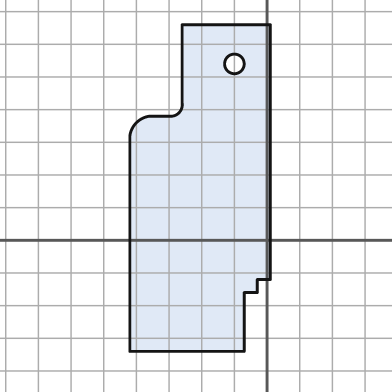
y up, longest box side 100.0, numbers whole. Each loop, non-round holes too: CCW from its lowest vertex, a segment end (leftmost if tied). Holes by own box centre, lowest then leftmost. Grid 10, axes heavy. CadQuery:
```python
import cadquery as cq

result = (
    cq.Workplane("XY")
    .moveTo(-42.0, -34.0)
    .lineTo(-7.0, -34.0)
    .lineTo(-7.0, -16.0)
    .lineTo(-3.0, -16.0)
    .lineTo(-3.0, -12.0)
    .lineTo(1.0, -12.0)
    .lineTo(1.0, 66.0)
    .lineTo(-26.0, 66.0)
    .lineTo(-26.0, 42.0)
    .threePointArc((-27.0, 39.0), (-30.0, 38.0))
    .lineTo(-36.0, 38.0)
    .threePointArc((-40.0, 36.0), (-42.0, 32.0))
    .close()
    .moveTo(-10.0, 54.0)
    .circle(3.0)
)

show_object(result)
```